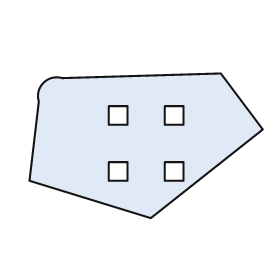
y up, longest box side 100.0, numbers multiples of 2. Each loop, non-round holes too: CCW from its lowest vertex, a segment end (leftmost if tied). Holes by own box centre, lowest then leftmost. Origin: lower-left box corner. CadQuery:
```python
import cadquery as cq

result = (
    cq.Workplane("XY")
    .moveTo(52.0, 0.0)
    .lineTo(100.0, 38.0)
    .lineTo(82.0, 62.0)
    .lineTo(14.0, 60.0)
    .threePointArc((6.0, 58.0), (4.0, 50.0))
    .lineTo(0.0, 16.0)
    .close()
    .moveTo(34.0, 16.0)
    .lineTo(42.0, 16.0)
    .lineTo(42.0, 24.0)
    .lineTo(34.0, 24.0)
    .close()
    .moveTo(58.0, 16.0)
    .lineTo(66.0, 16.0)
    .lineTo(66.0, 24.0)
    .lineTo(58.0, 24.0)
    .close()
    .moveTo(34.0, 40.0)
    .lineTo(42.0, 40.0)
    .lineTo(42.0, 48.0)
    .lineTo(34.0, 48.0)
    .close()
    .moveTo(58.0, 40.0)
    .lineTo(66.0, 40.0)
    .lineTo(66.0, 48.0)
    .lineTo(58.0, 48.0)
    .close()
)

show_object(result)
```